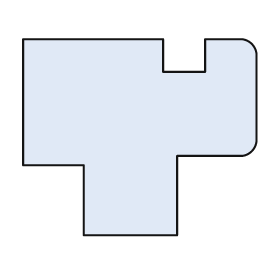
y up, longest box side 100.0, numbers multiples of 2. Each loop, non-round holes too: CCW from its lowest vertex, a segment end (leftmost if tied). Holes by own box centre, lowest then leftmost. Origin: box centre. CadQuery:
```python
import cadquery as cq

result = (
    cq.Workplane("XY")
    .moveTo(-24.0, -42.0)
    .lineTo(16.0, -42.0)
    .lineTo(16.0, -8.0)
    .lineTo(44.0, -8.0)
    .threePointArc((48.0, -6.0), (50.0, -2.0))
    .lineTo(50.0, 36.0)
    .threePointArc((48.0, 40.0), (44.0, 42.0))
    .lineTo(28.0, 42.0)
    .lineTo(28.0, 28.0)
    .lineTo(10.0, 28.0)
    .lineTo(10.0, 42.0)
    .lineTo(-50.0, 42.0)
    .lineTo(-50.0, -12.0)
    .lineTo(-24.0, -12.0)
    .close()
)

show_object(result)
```